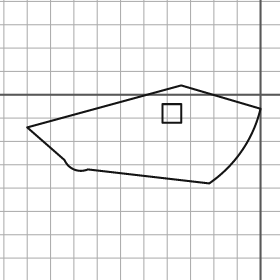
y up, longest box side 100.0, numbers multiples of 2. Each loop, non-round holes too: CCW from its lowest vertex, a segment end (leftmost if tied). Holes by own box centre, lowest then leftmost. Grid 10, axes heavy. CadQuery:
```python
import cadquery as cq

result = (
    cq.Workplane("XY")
    .moveTo(-22.0, -38.0)
    .threePointArc((-8.0, -24.0), (0.0, -6.0))
    .lineTo(-34.0, 4.0)
    .lineTo(-100.0, -14.0)
    .lineTo(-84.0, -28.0)
    .threePointArc((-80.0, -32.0), (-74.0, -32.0))
    .close()
    .moveTo(-42.0, -12.0)
    .lineTo(-34.0, -12.0)
    .lineTo(-34.0, -4.0)
    .lineTo(-42.0, -4.0)
    .close()
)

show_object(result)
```